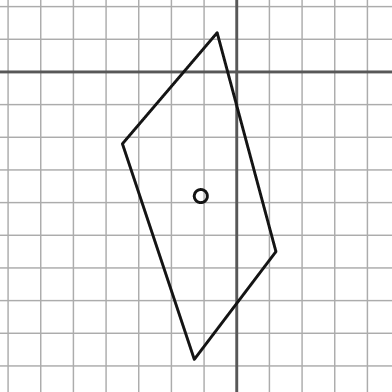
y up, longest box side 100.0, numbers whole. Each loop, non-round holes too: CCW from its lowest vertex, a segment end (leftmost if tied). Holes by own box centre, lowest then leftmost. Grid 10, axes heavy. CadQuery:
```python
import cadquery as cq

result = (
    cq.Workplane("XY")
    .moveTo(-13.0, -88.0)
    .lineTo(12.0, -55.0)
    .lineTo(-6.0, 12.0)
    .lineTo(-35.0, -22.0)
    .close()
    .moveTo(-11.0, -38.0)
    .circle(2.0)
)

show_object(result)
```